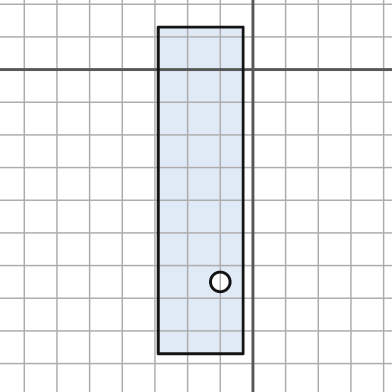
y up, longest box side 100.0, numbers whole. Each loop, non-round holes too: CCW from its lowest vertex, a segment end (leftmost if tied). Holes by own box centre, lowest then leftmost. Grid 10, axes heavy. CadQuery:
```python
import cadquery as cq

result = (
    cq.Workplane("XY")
    .moveTo(-29.0, -87.0)
    .lineTo(-3.0, -87.0)
    .lineTo(-3.0, 13.0)
    .lineTo(-29.0, 13.0)
    .close()
    .moveTo(-10.0, -65.0)
    .circle(3.0)
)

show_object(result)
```